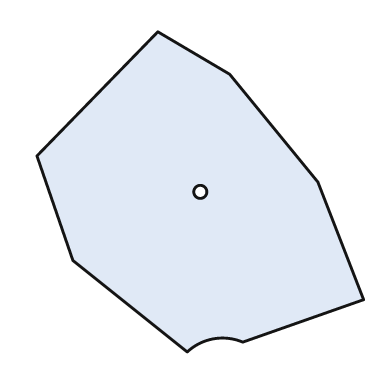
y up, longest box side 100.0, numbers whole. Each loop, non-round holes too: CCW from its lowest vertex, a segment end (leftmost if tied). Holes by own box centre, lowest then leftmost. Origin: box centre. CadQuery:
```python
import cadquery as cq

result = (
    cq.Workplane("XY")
    .moveTo(-4.0, -49.0)
    .threePointArc((4.0, -45.0), (13.0, -46.0))
    .lineTo(50.0, -33.0)
    .lineTo(36.0, 3.0)
    .lineTo(9.0, 36.0)
    .lineTo(-13.0, 49.0)
    .lineTo(-50.0, 11.0)
    .lineTo(-39.0, -21.0)
    .close()
    .moveTo(0.0, 0.0)
    .circle(2.0)
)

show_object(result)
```